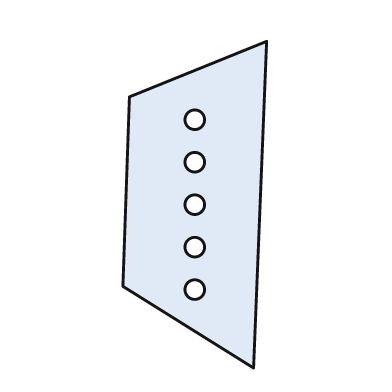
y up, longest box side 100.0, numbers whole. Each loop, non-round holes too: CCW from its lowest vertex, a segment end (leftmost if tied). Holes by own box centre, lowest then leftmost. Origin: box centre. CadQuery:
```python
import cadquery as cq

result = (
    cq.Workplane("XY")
    .moveTo(18.0, -50.0)
    .lineTo(22.0, 50.0)
    .lineTo(-20.0, 33.0)
    .lineTo(-22.0, -25.0)
    .close()
    .moveTo(0.0, -26.0)
    .circle(3.0)
    .moveTo(0.0, -13.0)
    .circle(3.0)
    .moveTo(0.0, 0.0)
    .circle(3.0)
    .moveTo(0.0, 13.0)
    .circle(3.0)
    .moveTo(0.0, 26.0)
    .circle(3.0)
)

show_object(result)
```